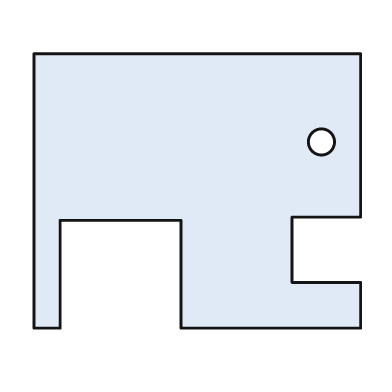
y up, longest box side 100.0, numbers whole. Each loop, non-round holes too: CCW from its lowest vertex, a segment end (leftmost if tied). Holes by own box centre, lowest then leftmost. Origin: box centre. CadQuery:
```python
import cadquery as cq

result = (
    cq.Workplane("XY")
    .moveTo(-50.0, -42.0)
    .lineTo(-42.0, -42.0)
    .lineTo(-42.0, -9.0)
    .lineTo(-5.0, -9.0)
    .lineTo(-5.0, -42.0)
    .lineTo(50.0, -42.0)
    .lineTo(50.0, -28.0)
    .lineTo(29.0, -28.0)
    .lineTo(29.0, -8.0)
    .lineTo(50.0, -8.0)
    .lineTo(50.0, 42.0)
    .lineTo(-50.0, 42.0)
    .close()
    .moveTo(38.0, 15.0)
    .circle(4.0)
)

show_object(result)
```